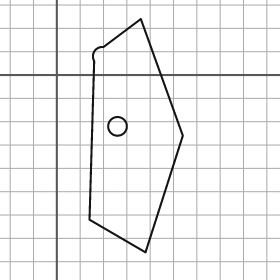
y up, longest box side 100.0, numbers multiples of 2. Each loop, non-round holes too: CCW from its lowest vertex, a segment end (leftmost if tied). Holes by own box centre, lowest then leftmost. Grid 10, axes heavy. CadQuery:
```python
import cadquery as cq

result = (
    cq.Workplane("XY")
    .moveTo(38.0, -76.0)
    .lineTo(54.0, -26.0)
    .lineTo(36.0, 24.0)
    .lineTo(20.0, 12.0)
    .threePointArc((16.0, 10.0), (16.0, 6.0))
    .lineTo(14.0, -62.0)
    .close()
    .moveTo(26.0, -22.0)
    .circle(4.0)
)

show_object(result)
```